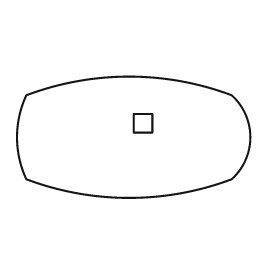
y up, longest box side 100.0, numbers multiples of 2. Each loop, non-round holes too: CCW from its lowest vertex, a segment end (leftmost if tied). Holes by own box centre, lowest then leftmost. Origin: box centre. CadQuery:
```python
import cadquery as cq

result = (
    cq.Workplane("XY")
    .moveTo(-46.0, -18.0)
    .threePointArc((-2.0, -26.0), (42.0, -18.0))
    .threePointArc((50.0, 0.0), (42.0, 18.0))
    .threePointArc((-2.0, 26.0), (-46.0, 18.0))
    .threePointArc((-50.0, 0.0), (-46.0, -18.0))
    .close()
    .moveTo(0.0, 2.0)
    .lineTo(8.0, 2.0)
    .lineTo(8.0, 10.0)
    .lineTo(0.0, 10.0)
    .close()
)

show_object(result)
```